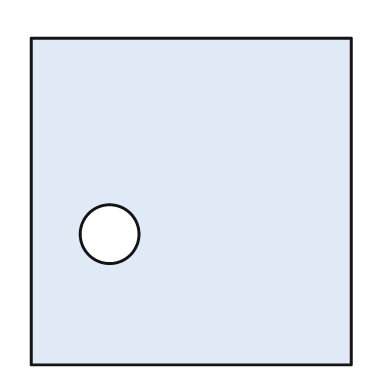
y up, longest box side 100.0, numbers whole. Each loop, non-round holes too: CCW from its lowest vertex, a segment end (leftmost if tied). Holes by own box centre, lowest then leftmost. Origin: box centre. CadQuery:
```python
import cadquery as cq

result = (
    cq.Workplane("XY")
    .moveTo(-49.0, -50.0)
    .lineTo(49.0, -50.0)
    .lineTo(49.0, 50.0)
    .lineTo(-49.0, 50.0)
    .close()
    .moveTo(-25.0, -10.0)
    .circle(9.0)
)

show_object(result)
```